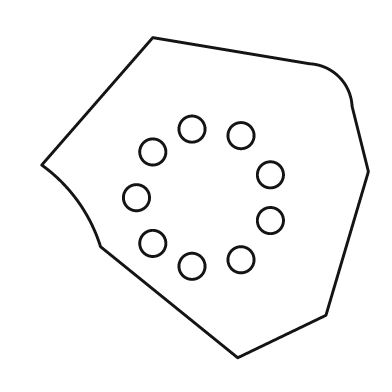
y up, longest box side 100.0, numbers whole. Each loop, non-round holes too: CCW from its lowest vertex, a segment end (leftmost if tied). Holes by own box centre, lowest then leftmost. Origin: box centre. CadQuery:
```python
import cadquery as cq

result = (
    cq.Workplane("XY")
    .moveTo(10.0, -49.0)
    .lineTo(37.0, -36.0)
    .lineTo(50.0, 8.0)
    .lineTo(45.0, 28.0)
    .threePointArc((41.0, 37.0), (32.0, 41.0))
    .lineTo(-16.0, 49.0)
    .lineTo(-50.0, 10.0)
    .threePointArc((-39.0, -1.0), (-32.0, -15.0))
    .close()
    .moveTo(-4.0, -21.0)
    .circle(4.0)
    .moveTo(11.0, -19.0)
    .circle(4.0)
    .moveTo(-16.0, -14.0)
    .circle(4.0)
    .moveTo(20.0, -7.0)
    .circle(4.0)
    .moveTo(-21.0, 0.0)
    .circle(4.0)
    .moveTo(20.0, 7.0)
    .circle(4.0)
    .moveTo(-16.0, 14.0)
    .circle(4.0)
    .moveTo(11.0, 19.0)
    .circle(4.0)
    .moveTo(-4.0, 21.0)
    .circle(4.0)
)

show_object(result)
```